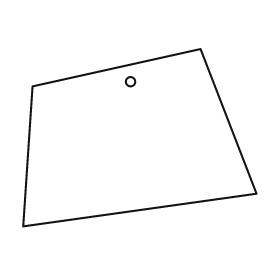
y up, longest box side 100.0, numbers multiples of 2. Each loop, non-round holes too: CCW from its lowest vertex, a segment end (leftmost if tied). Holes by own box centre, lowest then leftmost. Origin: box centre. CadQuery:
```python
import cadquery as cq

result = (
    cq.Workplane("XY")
    .moveTo(-50.0, -38.0)
    .lineTo(50.0, -24.0)
    .lineTo(26.0, 38.0)
    .lineTo(-46.0, 22.0)
    .close()
    .moveTo(-4.0, 24.0)
    .circle(2.0)
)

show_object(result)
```